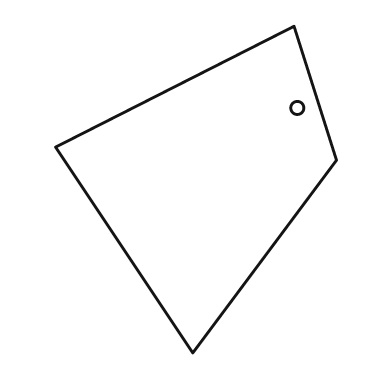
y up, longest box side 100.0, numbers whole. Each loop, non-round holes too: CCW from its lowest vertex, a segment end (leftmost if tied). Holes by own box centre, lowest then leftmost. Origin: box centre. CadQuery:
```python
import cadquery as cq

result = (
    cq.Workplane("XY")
    .moveTo(-1.0, -50.0)
    .lineTo(43.0, 9.0)
    .lineTo(30.0, 50.0)
    .lineTo(-43.0, 13.0)
    .close()
    .moveTo(31.0, 25.0)
    .circle(2.0)
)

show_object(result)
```